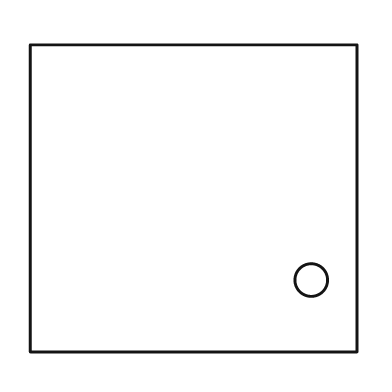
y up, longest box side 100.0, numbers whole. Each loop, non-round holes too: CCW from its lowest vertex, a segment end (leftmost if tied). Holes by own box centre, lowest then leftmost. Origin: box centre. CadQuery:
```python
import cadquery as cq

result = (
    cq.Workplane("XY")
    .moveTo(-50.0, -47.0)
    .lineTo(50.0, -47.0)
    .lineTo(50.0, 47.0)
    .lineTo(-50.0, 47.0)
    .close()
    .moveTo(36.0, -25.0)
    .circle(5.0)
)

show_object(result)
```